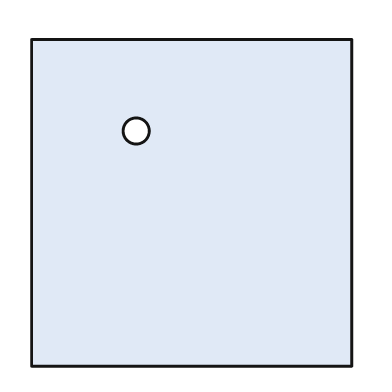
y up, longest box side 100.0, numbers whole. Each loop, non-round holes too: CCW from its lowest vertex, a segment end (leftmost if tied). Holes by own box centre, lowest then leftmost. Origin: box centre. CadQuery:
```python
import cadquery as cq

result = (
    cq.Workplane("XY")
    .moveTo(-49.0, -50.0)
    .lineTo(49.0, -50.0)
    .lineTo(49.0, 50.0)
    .lineTo(-49.0, 50.0)
    .close()
    .moveTo(-17.0, 22.0)
    .circle(4.0)
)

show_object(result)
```